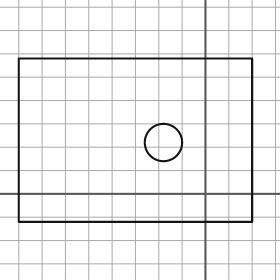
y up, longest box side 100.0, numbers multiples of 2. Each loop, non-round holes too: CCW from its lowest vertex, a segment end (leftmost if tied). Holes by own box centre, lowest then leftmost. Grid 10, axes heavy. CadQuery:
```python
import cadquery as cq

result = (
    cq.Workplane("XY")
    .moveTo(-80.0, -12.0)
    .lineTo(20.0, -12.0)
    .lineTo(20.0, 58.0)
    .lineTo(-80.0, 58.0)
    .close()
    .moveTo(-18.0, 22.0)
    .circle(8.0)
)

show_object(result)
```